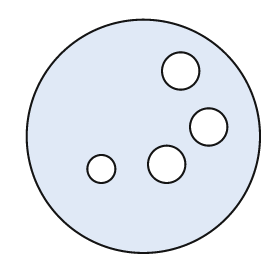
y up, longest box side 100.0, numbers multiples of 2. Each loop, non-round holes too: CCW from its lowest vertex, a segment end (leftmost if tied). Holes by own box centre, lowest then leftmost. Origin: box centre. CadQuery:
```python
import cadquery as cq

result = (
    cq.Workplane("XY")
    .moveTo(0.0, 0.0)
    .circle(50.0)
    .moveTo(-18.0, -14.0)
    .circle(6.0)
    .moveTo(10.0, -12.0)
    .circle(8.0)
    .moveTo(28.0, 4.0)
    .circle(8.0)
    .moveTo(16.0, 28.0)
    .circle(8.0)
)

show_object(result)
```